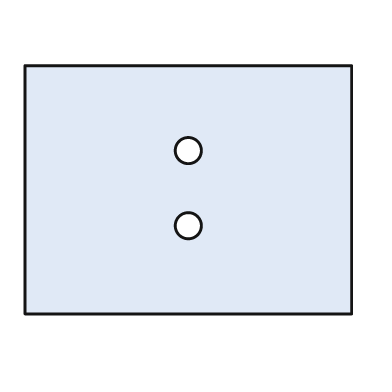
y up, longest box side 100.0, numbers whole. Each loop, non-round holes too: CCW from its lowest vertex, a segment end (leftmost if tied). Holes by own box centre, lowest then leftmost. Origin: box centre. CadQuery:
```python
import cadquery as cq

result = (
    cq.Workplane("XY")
    .moveTo(-50.0, -38.0)
    .lineTo(50.0, -38.0)
    .lineTo(50.0, 38.0)
    .lineTo(-50.0, 38.0)
    .close()
    .moveTo(0.0, -11.0)
    .circle(4.0)
    .moveTo(0.0, 12.0)
    .circle(4.0)
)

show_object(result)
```